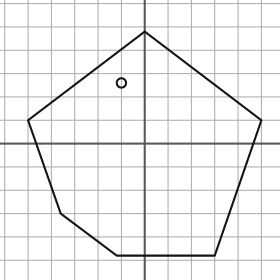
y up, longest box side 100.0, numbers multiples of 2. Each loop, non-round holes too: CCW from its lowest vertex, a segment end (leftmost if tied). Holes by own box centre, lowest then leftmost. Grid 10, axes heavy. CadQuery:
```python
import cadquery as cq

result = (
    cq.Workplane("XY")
    .moveTo(-12.0, -48.0)
    .lineTo(30.0, -48.0)
    .lineTo(50.0, 10.0)
    .lineTo(0.0, 48.0)
    .lineTo(-50.0, 10.0)
    .lineTo(-36.0, -30.0)
    .close()
    .moveTo(-10.0, 26.0)
    .circle(2.0)
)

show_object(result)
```